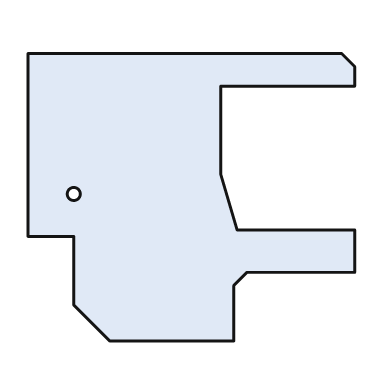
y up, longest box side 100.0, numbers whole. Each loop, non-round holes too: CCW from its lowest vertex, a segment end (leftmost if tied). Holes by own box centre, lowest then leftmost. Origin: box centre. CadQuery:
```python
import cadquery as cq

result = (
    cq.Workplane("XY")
    .moveTo(-25.0, -44.0)
    .lineTo(13.0, -44.0)
    .lineTo(13.0, -27.0)
    .lineTo(17.0, -23.0)
    .lineTo(50.0, -23.0)
    .lineTo(50.0, -10.0)
    .lineTo(14.0, -10.0)
    .lineTo(9.0, 7.0)
    .lineTo(9.0, 34.0)
    .lineTo(50.0, 34.0)
    .lineTo(50.0, 40.0)
    .lineTo(46.0, 44.0)
    .lineTo(-50.0, 44.0)
    .lineTo(-50.0, -12.0)
    .lineTo(-36.0, -12.0)
    .lineTo(-36.0, -33.0)
    .close()
    .moveTo(-36.0, 1.0)
    .circle(2.0)
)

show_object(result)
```